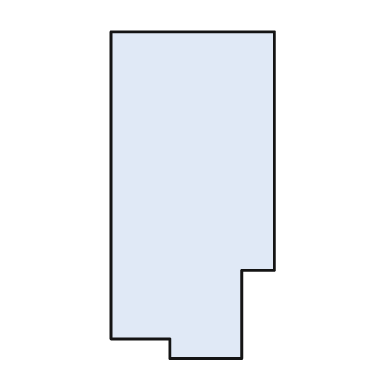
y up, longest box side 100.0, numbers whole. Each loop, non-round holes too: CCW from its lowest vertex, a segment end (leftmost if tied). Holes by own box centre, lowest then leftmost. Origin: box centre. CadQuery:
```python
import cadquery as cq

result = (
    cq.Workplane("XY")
    .moveTo(-7.0, -50.0)
    .lineTo(15.0, -50.0)
    .lineTo(15.0, -23.0)
    .lineTo(25.0, -23.0)
    .lineTo(25.0, 50.0)
    .lineTo(-25.0, 50.0)
    .lineTo(-25.0, -44.0)
    .lineTo(-7.0, -44.0)
    .close()
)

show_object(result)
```